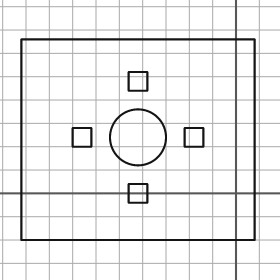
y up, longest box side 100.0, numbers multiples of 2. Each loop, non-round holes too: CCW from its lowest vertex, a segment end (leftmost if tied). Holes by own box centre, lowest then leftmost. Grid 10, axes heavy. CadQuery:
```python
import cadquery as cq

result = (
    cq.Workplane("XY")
    .moveTo(-92.0, -20.0)
    .lineTo(8.0, -20.0)
    .lineTo(8.0, 66.0)
    .lineTo(-92.0, 66.0)
    .close()
    .moveTo(-46.0, -4.0)
    .lineTo(-38.0, -4.0)
    .lineTo(-38.0, 4.0)
    .lineTo(-46.0, 4.0)
    .close()
    .moveTo(-70.0, 20.0)
    .lineTo(-62.0, 20.0)
    .lineTo(-62.0, 28.0)
    .lineTo(-70.0, 28.0)
    .close()
    .moveTo(-42.0, 24.0)
    .circle(12.0)
    .moveTo(-22.0, 20.0)
    .lineTo(-14.0, 20.0)
    .lineTo(-14.0, 28.0)
    .lineTo(-22.0, 28.0)
    .close()
    .moveTo(-46.0, 44.0)
    .lineTo(-38.0, 44.0)
    .lineTo(-38.0, 52.0)
    .lineTo(-46.0, 52.0)
    .close()
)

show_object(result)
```